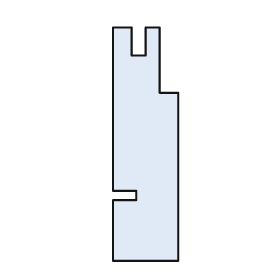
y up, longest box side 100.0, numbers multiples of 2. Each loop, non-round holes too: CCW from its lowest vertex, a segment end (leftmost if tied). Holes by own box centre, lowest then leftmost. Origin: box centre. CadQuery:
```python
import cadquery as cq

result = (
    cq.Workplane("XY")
    .moveTo(-14.0, -50.0)
    .lineTo(14.0, -50.0)
    .lineTo(14.0, 22.0)
    .lineTo(6.0, 22.0)
    .lineTo(6.0, 50.0)
    .lineTo(0.0, 50.0)
    .lineTo(0.0, 38.0)
    .lineTo(-6.0, 38.0)
    .lineTo(-6.0, 50.0)
    .lineTo(-14.0, 50.0)
    .lineTo(-14.0, -20.0)
    .lineTo(-4.0, -20.0)
    .lineTo(-4.0, -24.0)
    .lineTo(-14.0, -24.0)
    .close()
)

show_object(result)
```